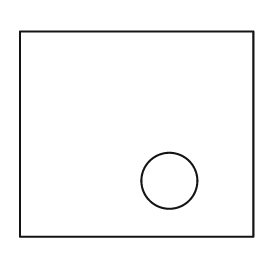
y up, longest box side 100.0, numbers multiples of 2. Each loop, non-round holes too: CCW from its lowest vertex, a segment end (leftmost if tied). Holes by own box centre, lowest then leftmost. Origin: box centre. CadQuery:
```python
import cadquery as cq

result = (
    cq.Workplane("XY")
    .moveTo(-50.0, -44.0)
    .lineTo(50.0, -44.0)
    .lineTo(50.0, 44.0)
    .lineTo(-50.0, 44.0)
    .close()
    .moveTo(14.0, -20.0)
    .circle(12.0)
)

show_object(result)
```